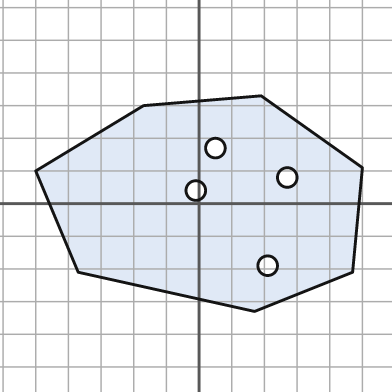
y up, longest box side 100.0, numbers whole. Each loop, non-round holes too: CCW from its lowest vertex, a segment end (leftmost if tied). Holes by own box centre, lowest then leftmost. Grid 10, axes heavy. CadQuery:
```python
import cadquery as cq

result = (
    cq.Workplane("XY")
    .moveTo(17.0, -33.0)
    .lineTo(47.0, -21.0)
    .lineTo(50.0, 11.0)
    .lineTo(19.0, 33.0)
    .lineTo(-17.0, 30.0)
    .lineTo(-50.0, 10.0)
    .lineTo(-37.0, -21.0)
    .close()
    .moveTo(21.0, -19.0)
    .circle(3.0)
    .moveTo(-1.0, 4.0)
    .circle(3.0)
    .moveTo(27.0, 8.0)
    .circle(3.0)
    .moveTo(5.0, 17.0)
    .circle(3.0)
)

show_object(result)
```